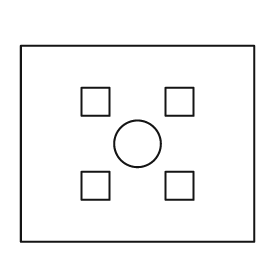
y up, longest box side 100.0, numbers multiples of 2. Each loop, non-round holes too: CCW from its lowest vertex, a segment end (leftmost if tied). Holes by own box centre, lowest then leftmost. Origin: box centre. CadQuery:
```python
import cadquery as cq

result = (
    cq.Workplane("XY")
    .moveTo(-50.0, -42.0)
    .lineTo(50.0, -42.0)
    .lineTo(50.0, 42.0)
    .lineTo(-50.0, 42.0)
    .close()
    .moveTo(-24.0, -24.0)
    .lineTo(-12.0, -24.0)
    .lineTo(-12.0, -12.0)
    .lineTo(-24.0, -12.0)
    .close()
    .moveTo(12.0, -24.0)
    .lineTo(24.0, -24.0)
    .lineTo(24.0, -12.0)
    .lineTo(12.0, -12.0)
    .close()
    .moveTo(0.0, 0.0)
    .circle(10.0)
    .moveTo(-24.0, 12.0)
    .lineTo(-12.0, 12.0)
    .lineTo(-12.0, 24.0)
    .lineTo(-24.0, 24.0)
    .close()
    .moveTo(12.0, 12.0)
    .lineTo(24.0, 12.0)
    .lineTo(24.0, 24.0)
    .lineTo(12.0, 24.0)
    .close()
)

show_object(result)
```